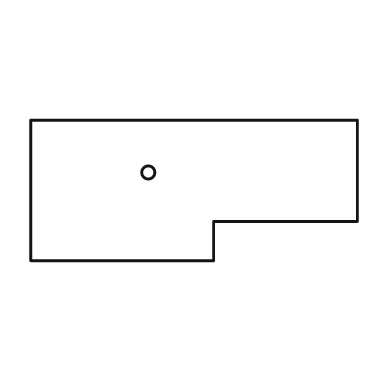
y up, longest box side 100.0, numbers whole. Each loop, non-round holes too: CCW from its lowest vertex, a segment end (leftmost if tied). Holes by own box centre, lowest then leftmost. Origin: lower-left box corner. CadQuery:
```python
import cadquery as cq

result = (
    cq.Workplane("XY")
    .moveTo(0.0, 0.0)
    .lineTo(56.0, 0.0)
    .lineTo(56.0, 12.0)
    .lineTo(100.0, 12.0)
    .lineTo(100.0, 43.0)
    .lineTo(0.0, 43.0)
    .close()
    .moveTo(36.0, 27.0)
    .circle(2.0)
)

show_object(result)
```